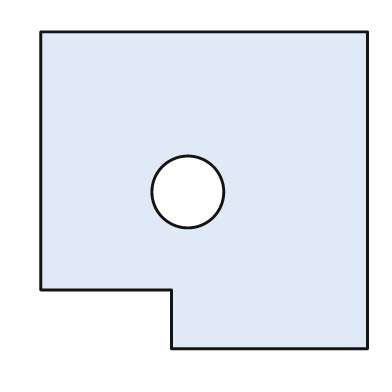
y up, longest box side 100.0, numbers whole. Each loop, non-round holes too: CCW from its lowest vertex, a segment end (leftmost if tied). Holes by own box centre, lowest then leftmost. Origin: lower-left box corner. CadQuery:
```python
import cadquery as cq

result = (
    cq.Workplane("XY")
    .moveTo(40.0, 0.0)
    .lineTo(100.0, 0.0)
    .lineTo(100.0, 97.0)
    .lineTo(0.0, 97.0)
    .lineTo(0.0, 18.0)
    .lineTo(40.0, 18.0)
    .close()
    .moveTo(45.0, 48.0)
    .circle(11.0)
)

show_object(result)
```